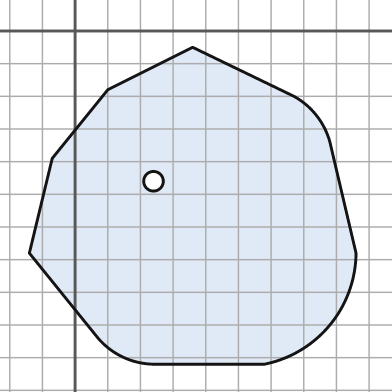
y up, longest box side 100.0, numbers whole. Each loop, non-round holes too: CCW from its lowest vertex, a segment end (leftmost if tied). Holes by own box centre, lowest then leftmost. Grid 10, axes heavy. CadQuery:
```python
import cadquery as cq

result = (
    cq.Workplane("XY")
    .moveTo(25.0, -102.0)
    .lineTo(58.0, -102.0)
    .threePointArc((78.0, -90.0), (86.0, -68.0))
    .lineTo(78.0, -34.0)
    .threePointArc((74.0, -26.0), (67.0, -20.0))
    .lineTo(36.0, -5.0)
    .lineTo(10.0, -18.0)
    .lineTo(-7.0, -39.0)
    .lineTo(-14.0, -68.0)
    .lineTo(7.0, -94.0)
    .threePointArc((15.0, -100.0), (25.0, -102.0))
    .close()
    .moveTo(24.0, -46.0)
    .circle(3.0)
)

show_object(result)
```